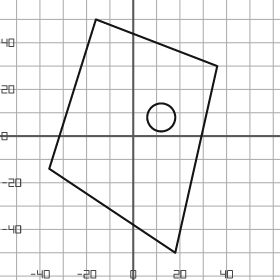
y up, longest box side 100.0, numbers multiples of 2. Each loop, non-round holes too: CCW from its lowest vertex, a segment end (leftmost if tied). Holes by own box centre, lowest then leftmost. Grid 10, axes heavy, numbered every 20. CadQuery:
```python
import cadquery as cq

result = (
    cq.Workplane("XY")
    .moveTo(18.0, -50.0)
    .lineTo(36.0, 30.0)
    .lineTo(-16.0, 50.0)
    .lineTo(-36.0, -14.0)
    .close()
    .moveTo(12.0, 8.0)
    .circle(6.0)
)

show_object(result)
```